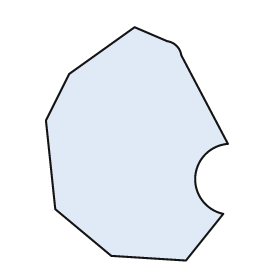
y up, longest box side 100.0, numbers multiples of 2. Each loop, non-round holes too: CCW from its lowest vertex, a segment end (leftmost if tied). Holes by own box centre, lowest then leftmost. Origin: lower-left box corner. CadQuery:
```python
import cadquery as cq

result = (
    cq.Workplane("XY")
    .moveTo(60.0, 0.0)
    .lineTo(76.0, 20.0)
    .threePointArc((64.0, 36.0), (78.0, 50.0))
    .lineTo(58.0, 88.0)
    .threePointArc((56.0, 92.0), (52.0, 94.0))
    .lineTo(38.0, 100.0)
    .lineTo(10.0, 80.0)
    .lineTo(0.0, 60.0)
    .lineTo(4.0, 22.0)
    .lineTo(28.0, 2.0)
    .close()
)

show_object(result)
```